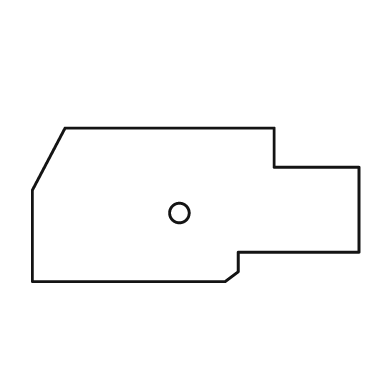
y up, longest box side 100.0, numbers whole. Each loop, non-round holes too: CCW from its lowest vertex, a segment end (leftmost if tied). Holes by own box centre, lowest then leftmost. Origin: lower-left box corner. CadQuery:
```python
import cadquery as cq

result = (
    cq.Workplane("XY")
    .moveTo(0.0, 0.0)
    .lineTo(59.0, 0.0)
    .lineTo(63.0, 3.0)
    .lineTo(63.0, 9.0)
    .lineTo(100.0, 9.0)
    .lineTo(100.0, 35.0)
    .lineTo(74.0, 35.0)
    .lineTo(74.0, 47.0)
    .lineTo(10.0, 47.0)
    .lineTo(0.0, 28.0)
    .close()
    .moveTo(45.0, 21.0)
    .circle(3.0)
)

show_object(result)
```